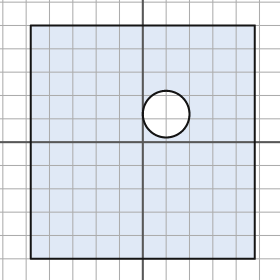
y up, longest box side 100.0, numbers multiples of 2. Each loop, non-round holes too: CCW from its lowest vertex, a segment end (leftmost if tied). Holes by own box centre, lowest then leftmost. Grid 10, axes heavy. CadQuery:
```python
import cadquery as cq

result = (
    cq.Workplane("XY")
    .moveTo(-48.0, -50.0)
    .lineTo(48.0, -50.0)
    .lineTo(48.0, 50.0)
    .lineTo(-48.0, 50.0)
    .close()
    .moveTo(10.0, 12.0)
    .circle(10.0)
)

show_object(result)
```